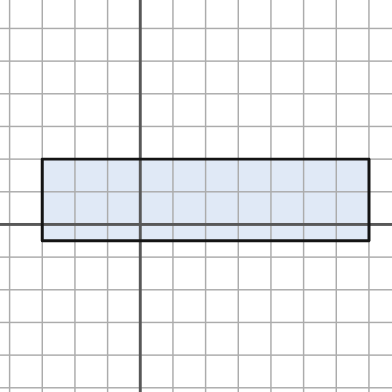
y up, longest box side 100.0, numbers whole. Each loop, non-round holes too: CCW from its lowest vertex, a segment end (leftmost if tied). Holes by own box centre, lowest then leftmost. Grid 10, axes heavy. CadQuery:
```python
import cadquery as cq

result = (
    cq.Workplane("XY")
    .moveTo(-30.0, -5.0)
    .lineTo(70.0, -5.0)
    .lineTo(70.0, 20.0)
    .lineTo(-30.0, 20.0)
    .close()
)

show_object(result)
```